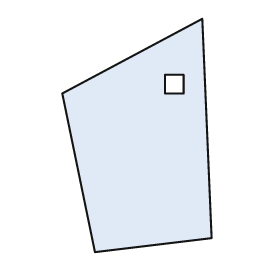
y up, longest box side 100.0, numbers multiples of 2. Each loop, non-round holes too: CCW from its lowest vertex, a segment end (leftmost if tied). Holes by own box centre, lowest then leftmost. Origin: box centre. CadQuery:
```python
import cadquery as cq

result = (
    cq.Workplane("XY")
    .moveTo(-18.0, -50.0)
    .lineTo(32.0, -44.0)
    .lineTo(28.0, 50.0)
    .lineTo(-32.0, 18.0)
    .close()
    .moveTo(12.0, 18.0)
    .lineTo(20.0, 18.0)
    .lineTo(20.0, 26.0)
    .lineTo(12.0, 26.0)
    .close()
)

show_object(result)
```